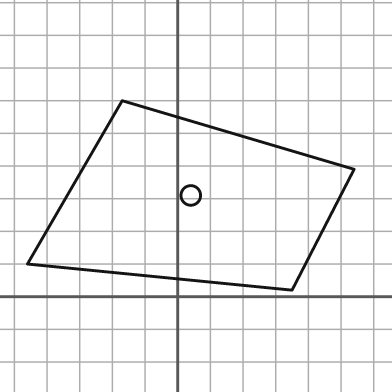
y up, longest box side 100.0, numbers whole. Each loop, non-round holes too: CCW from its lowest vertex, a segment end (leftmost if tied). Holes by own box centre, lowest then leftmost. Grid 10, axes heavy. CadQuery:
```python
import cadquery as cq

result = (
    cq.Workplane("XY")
    .moveTo(35.0, 2.0)
    .lineTo(54.0, 39.0)
    .lineTo(-17.0, 60.0)
    .lineTo(-46.0, 10.0)
    .close()
    .moveTo(4.0, 31.0)
    .circle(3.0)
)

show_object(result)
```